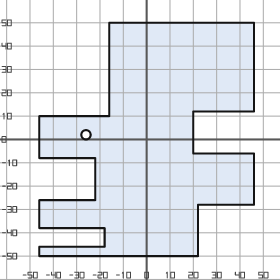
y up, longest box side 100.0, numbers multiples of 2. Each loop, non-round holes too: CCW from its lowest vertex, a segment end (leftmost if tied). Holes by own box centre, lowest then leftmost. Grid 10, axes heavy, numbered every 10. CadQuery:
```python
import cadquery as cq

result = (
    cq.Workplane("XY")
    .moveTo(-46.0, -50.0)
    .lineTo(22.0, -50.0)
    .lineTo(22.0, -28.0)
    .lineTo(46.0, -28.0)
    .lineTo(46.0, -6.0)
    .lineTo(20.0, -6.0)
    .lineTo(20.0, 12.0)
    .lineTo(46.0, 12.0)
    .lineTo(46.0, 50.0)
    .lineTo(-16.0, 50.0)
    .lineTo(-16.0, 10.0)
    .lineTo(-46.0, 10.0)
    .lineTo(-46.0, -8.0)
    .lineTo(-22.0, -8.0)
    .lineTo(-22.0, -26.0)
    .lineTo(-46.0, -26.0)
    .lineTo(-46.0, -38.0)
    .lineTo(-18.0, -38.0)
    .lineTo(-18.0, -46.0)
    .lineTo(-46.0, -46.0)
    .close()
    .moveTo(-26.0, 2.0)
    .circle(2.0)
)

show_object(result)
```